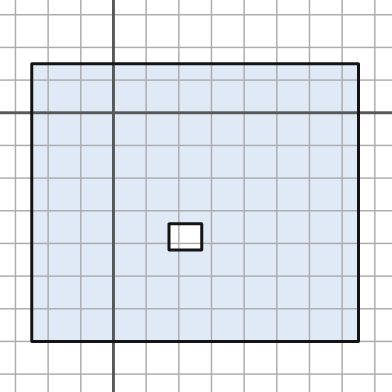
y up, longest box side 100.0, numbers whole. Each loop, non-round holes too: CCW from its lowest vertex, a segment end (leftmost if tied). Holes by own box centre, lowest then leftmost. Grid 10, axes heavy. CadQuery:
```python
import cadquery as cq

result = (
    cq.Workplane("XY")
    .moveTo(-25.0, -70.0)
    .lineTo(75.0, -70.0)
    .lineTo(75.0, 15.0)
    .lineTo(-25.0, 15.0)
    .close()
    .moveTo(17.0, -42.0)
    .lineTo(27.0, -42.0)
    .lineTo(27.0, -34.0)
    .lineTo(17.0, -34.0)
    .close()
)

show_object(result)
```